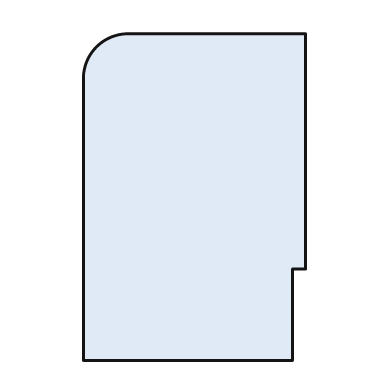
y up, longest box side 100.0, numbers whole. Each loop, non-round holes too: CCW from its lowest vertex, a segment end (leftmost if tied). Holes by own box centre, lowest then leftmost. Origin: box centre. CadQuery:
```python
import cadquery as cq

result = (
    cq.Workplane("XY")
    .moveTo(-34.0, -50.0)
    .lineTo(30.0, -50.0)
    .lineTo(30.0, -22.0)
    .lineTo(34.0, -22.0)
    .lineTo(34.0, 50.0)
    .lineTo(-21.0, 50.0)
    .threePointArc((-30.0, 46.0), (-34.0, 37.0))
    .close()
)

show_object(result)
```